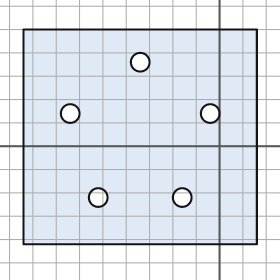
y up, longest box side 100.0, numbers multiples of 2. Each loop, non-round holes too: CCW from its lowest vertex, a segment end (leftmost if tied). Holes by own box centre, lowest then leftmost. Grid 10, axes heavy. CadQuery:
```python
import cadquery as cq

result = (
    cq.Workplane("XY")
    .moveTo(-84.0, -42.0)
    .lineTo(16.0, -42.0)
    .lineTo(16.0, 50.0)
    .lineTo(-84.0, 50.0)
    .close()
    .moveTo(-52.0, -22.0)
    .circle(4.0)
    .moveTo(-16.0, -22.0)
    .circle(4.0)
    .moveTo(-64.0, 14.0)
    .circle(4.0)
    .moveTo(-4.0, 14.0)
    .circle(4.0)
    .moveTo(-34.0, 36.0)
    .circle(4.0)
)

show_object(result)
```